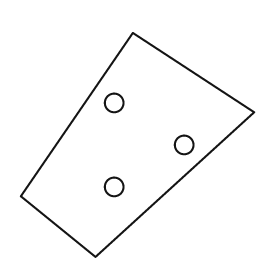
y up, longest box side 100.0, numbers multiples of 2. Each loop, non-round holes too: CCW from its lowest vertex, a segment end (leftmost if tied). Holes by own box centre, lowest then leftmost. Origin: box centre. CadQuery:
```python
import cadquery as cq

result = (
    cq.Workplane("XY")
    .moveTo(-18.0, -48.0)
    .lineTo(50.0, 14.0)
    .lineTo(-2.0, 48.0)
    .lineTo(-50.0, -22.0)
    .close()
    .moveTo(-10.0, -18.0)
    .circle(4.0)
    .moveTo(20.0, 0.0)
    .circle(4.0)
    .moveTo(-10.0, 18.0)
    .circle(4.0)
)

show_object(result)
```